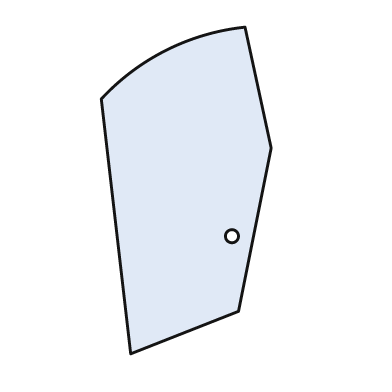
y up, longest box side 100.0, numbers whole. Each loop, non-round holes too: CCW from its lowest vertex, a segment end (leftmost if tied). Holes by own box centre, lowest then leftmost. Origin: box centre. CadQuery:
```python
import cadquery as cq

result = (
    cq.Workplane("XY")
    .moveTo(-17.0, -50.0)
    .lineTo(16.0, -37.0)
    .lineTo(26.0, 13.0)
    .lineTo(18.0, 50.0)
    .threePointArc((-6.0, 43.0), (-26.0, 28.0))
    .close()
    .moveTo(14.0, -14.0)
    .circle(2.0)
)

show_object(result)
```